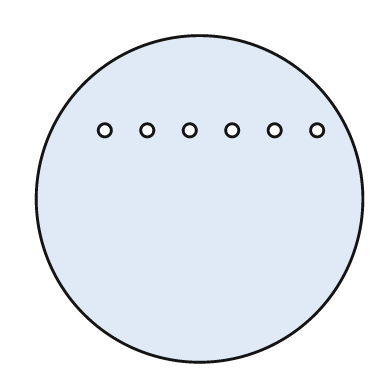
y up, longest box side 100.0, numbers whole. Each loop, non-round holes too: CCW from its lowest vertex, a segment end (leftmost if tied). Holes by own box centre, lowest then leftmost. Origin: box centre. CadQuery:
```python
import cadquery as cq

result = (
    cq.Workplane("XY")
    .moveTo(0.0, 0.0)
    .circle(50.0)
    .moveTo(-29.0, 21.0)
    .circle(2.0)
    .moveTo(-16.0, 21.0)
    .circle(2.0)
    .moveTo(-3.0, 21.0)
    .circle(2.0)
    .moveTo(10.0, 21.0)
    .circle(2.0)
    .moveTo(23.0, 21.0)
    .circle(2.0)
    .moveTo(36.0, 21.0)
    .circle(2.0)
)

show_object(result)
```